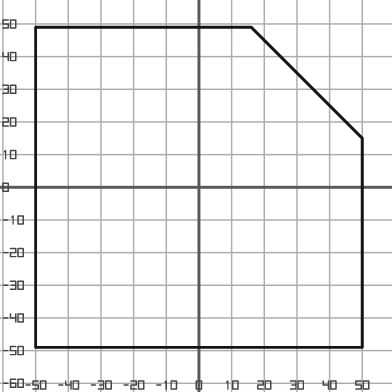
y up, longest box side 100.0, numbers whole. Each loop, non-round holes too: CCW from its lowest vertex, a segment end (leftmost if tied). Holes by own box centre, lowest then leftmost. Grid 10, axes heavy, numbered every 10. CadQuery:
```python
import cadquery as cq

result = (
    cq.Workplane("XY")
    .moveTo(-50.0, -49.0)
    .lineTo(50.0, -49.0)
    .lineTo(50.0, 15.0)
    .lineTo(16.0, 49.0)
    .lineTo(-50.0, 49.0)
    .close()
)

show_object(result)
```